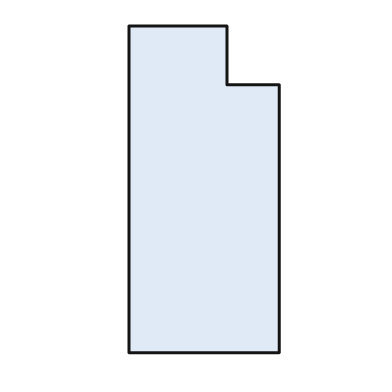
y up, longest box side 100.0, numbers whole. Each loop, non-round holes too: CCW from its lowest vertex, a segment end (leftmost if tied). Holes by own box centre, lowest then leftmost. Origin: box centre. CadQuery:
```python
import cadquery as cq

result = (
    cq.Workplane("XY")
    .moveTo(-23.0, -50.0)
    .lineTo(23.0, -50.0)
    .lineTo(23.0, 32.0)
    .lineTo(7.0, 32.0)
    .lineTo(7.0, 50.0)
    .lineTo(-23.0, 50.0)
    .close()
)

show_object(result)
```